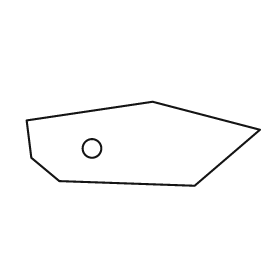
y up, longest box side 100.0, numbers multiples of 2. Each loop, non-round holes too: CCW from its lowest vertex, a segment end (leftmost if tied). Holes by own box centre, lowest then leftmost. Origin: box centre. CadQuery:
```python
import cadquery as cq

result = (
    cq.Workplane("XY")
    .moveTo(22.0, -18.0)
    .lineTo(50.0, 6.0)
    .lineTo(4.0, 18.0)
    .lineTo(-50.0, 10.0)
    .lineTo(-48.0, -6.0)
    .lineTo(-36.0, -16.0)
    .close()
    .moveTo(-22.0, -2.0)
    .circle(4.0)
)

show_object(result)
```